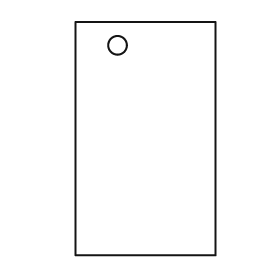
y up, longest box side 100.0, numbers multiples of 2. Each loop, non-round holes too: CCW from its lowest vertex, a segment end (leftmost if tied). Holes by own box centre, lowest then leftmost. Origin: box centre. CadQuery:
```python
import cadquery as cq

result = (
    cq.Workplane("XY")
    .moveTo(-30.0, -50.0)
    .lineTo(30.0, -50.0)
    .lineTo(30.0, 50.0)
    .lineTo(-30.0, 50.0)
    .close()
    .moveTo(-12.0, 40.0)
    .circle(4.0)
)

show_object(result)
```